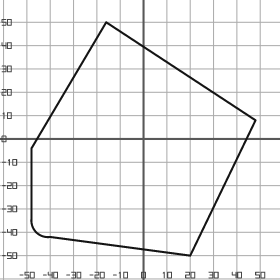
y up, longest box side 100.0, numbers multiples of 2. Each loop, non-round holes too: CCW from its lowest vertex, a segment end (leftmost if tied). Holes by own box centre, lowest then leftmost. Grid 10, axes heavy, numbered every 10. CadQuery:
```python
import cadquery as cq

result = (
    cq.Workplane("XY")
    .moveTo(20.0, -50.0)
    .lineTo(48.0, 8.0)
    .lineTo(-16.0, 50.0)
    .lineTo(-48.0, -4.0)
    .lineTo(-48.0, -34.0)
    .threePointArc((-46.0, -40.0), (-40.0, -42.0))
    .close()
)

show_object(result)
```